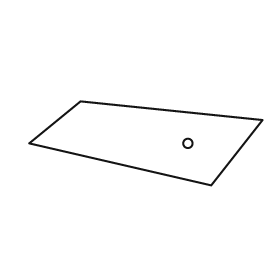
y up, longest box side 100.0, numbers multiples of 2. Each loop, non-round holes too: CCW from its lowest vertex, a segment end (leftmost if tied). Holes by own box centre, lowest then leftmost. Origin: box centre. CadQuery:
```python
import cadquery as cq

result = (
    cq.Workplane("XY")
    .moveTo(28.0, -18.0)
    .lineTo(50.0, 10.0)
    .lineTo(-28.0, 18.0)
    .lineTo(-50.0, 0.0)
    .close()
    .moveTo(18.0, 0.0)
    .circle(2.0)
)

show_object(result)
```